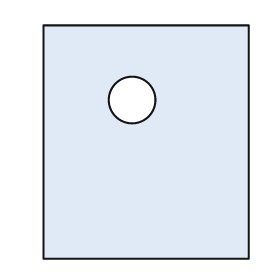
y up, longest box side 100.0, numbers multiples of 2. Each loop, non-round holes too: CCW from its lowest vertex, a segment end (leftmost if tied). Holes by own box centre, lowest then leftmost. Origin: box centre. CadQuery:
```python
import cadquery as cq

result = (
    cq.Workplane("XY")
    .moveTo(-44.0, -50.0)
    .lineTo(44.0, -50.0)
    .lineTo(44.0, 50.0)
    .lineTo(-44.0, 50.0)
    .close()
    .moveTo(-6.0, 18.0)
    .circle(10.0)
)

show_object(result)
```